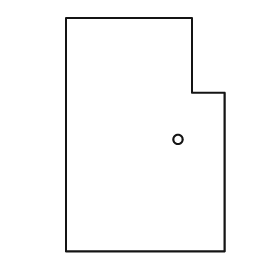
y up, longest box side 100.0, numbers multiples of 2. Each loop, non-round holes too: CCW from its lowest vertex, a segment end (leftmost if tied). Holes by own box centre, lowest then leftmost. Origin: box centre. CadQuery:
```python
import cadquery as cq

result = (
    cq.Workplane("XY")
    .moveTo(-34.0, -50.0)
    .lineTo(34.0, -50.0)
    .lineTo(34.0, 18.0)
    .lineTo(20.0, 18.0)
    .lineTo(20.0, 50.0)
    .lineTo(-34.0, 50.0)
    .close()
    .moveTo(14.0, -2.0)
    .circle(2.0)
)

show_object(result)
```